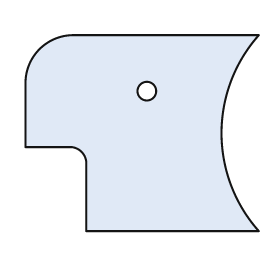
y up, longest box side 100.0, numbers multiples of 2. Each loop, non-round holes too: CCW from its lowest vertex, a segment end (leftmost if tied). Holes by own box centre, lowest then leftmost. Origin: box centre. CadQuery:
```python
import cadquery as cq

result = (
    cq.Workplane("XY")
    .moveTo(-24.0, -42.0)
    .lineTo(50.0, -42.0)
    .threePointArc((34.0, 0.0), (50.0, 42.0))
    .lineTo(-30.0, 42.0)
    .threePointArc((-44.0, 36.0), (-50.0, 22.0))
    .lineTo(-50.0, -6.0)
    .lineTo(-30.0, -6.0)
    .threePointArc((-26.0, -8.0), (-24.0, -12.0))
    .close()
    .moveTo(2.0, 18.0)
    .circle(4.0)
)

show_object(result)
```